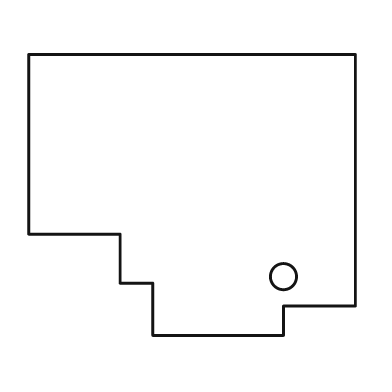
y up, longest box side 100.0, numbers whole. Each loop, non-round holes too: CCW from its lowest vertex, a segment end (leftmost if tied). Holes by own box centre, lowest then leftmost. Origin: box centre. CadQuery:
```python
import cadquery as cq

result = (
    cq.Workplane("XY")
    .moveTo(-12.0, -43.0)
    .lineTo(28.0, -43.0)
    .lineTo(28.0, -34.0)
    .lineTo(50.0, -34.0)
    .lineTo(50.0, 43.0)
    .lineTo(-50.0, 43.0)
    .lineTo(-50.0, -12.0)
    .lineTo(-22.0, -12.0)
    .lineTo(-22.0, -27.0)
    .lineTo(-12.0, -27.0)
    .close()
    .moveTo(28.0, -25.0)
    .circle(4.0)
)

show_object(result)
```